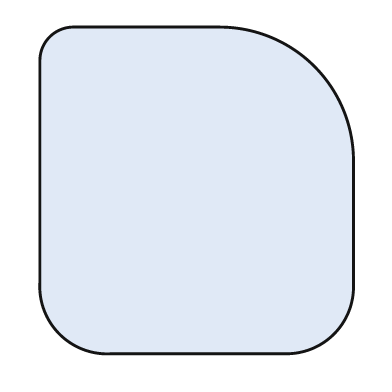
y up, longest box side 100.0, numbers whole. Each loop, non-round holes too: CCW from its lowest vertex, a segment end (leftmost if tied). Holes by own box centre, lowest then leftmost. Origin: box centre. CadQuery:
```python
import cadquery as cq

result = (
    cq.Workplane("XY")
    .moveTo(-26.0, -50.0)
    .lineTo(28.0, -50.0)
    .threePointArc((42.0, -44.0), (48.0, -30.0))
    .lineTo(48.0, 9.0)
    .threePointArc((36.0, 38.0), (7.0, 50.0))
    .lineTo(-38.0, 50.0)
    .threePointArc((-45.0, 47.0), (-48.0, 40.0))
    .lineTo(-48.0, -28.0)
    .threePointArc((-42.0, -44.0), (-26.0, -50.0))
    .close()
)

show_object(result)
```